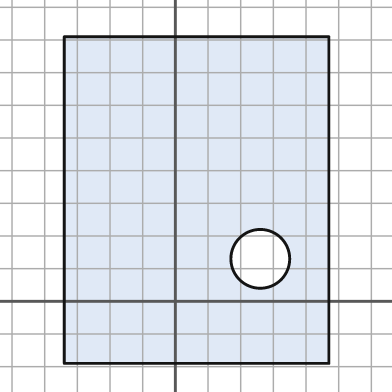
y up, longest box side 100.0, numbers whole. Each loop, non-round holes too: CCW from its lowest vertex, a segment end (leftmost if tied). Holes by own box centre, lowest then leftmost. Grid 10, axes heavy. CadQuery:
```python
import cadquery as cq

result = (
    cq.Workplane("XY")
    .moveTo(-34.0, -19.0)
    .lineTo(47.0, -19.0)
    .lineTo(47.0, 81.0)
    .lineTo(-34.0, 81.0)
    .close()
    .moveTo(26.0, 13.0)
    .circle(9.0)
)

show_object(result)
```